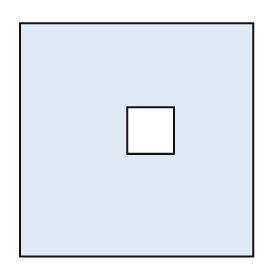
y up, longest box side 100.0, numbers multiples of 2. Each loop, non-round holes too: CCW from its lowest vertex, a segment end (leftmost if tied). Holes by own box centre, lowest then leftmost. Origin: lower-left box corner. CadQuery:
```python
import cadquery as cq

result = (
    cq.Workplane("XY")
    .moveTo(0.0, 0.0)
    .lineTo(100.0, 0.0)
    .lineTo(100.0, 100.0)
    .lineTo(0.0, 100.0)
    .close()
    .moveTo(46.0, 44.0)
    .lineTo(66.0, 44.0)
    .lineTo(66.0, 64.0)
    .lineTo(46.0, 64.0)
    .close()
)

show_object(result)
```